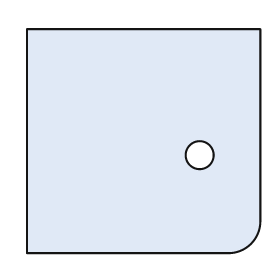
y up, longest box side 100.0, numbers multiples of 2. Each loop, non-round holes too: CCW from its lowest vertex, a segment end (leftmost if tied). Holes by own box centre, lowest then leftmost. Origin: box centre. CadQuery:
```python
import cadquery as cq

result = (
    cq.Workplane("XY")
    .moveTo(-50.0, -48.0)
    .lineTo(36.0, -48.0)
    .threePointArc((46.0, -44.0), (50.0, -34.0))
    .lineTo(50.0, 48.0)
    .lineTo(-50.0, 48.0)
    .close()
    .moveTo(24.0, -6.0)
    .circle(6.0)
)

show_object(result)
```